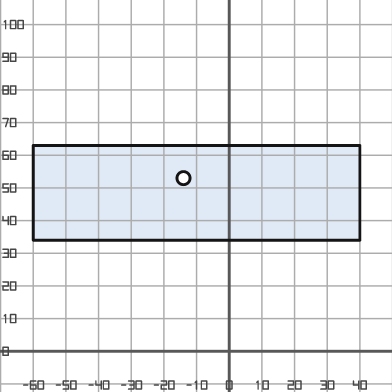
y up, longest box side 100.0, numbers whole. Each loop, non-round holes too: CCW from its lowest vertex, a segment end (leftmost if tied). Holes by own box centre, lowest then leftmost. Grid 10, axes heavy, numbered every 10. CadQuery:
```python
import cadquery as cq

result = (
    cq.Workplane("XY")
    .moveTo(-60.0, 34.0)
    .lineTo(40.0, 34.0)
    .lineTo(40.0, 63.0)
    .lineTo(-60.0, 63.0)
    .close()
    .moveTo(-14.0, 53.0)
    .circle(2.0)
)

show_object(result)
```